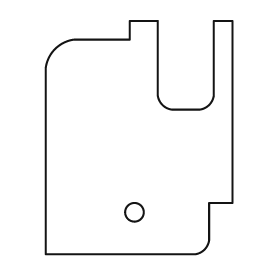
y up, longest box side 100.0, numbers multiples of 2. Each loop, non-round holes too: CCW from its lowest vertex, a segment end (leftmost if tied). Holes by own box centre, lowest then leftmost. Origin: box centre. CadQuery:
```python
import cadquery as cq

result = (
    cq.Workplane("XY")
    .moveTo(-40.0, -50.0)
    .lineTo(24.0, -50.0)
    .threePointArc((28.0, -48.0), (30.0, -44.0))
    .lineTo(30.0, -28.0)
    .lineTo(40.0, -28.0)
    .lineTo(40.0, 50.0)
    .lineTo(32.0, 50.0)
    .lineTo(32.0, 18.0)
    .threePointArc((30.0, 14.0), (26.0, 12.0))
    .lineTo(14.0, 12.0)
    .threePointArc((10.0, 14.0), (8.0, 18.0))
    .lineTo(8.0, 50.0)
    .lineTo(-4.0, 50.0)
    .lineTo(-4.0, 42.0)
    .lineTo(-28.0, 42.0)
    .threePointArc((-36.0, 38.0), (-40.0, 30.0))
    .close()
    .moveTo(-2.0, -32.0)
    .circle(4.0)
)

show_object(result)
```